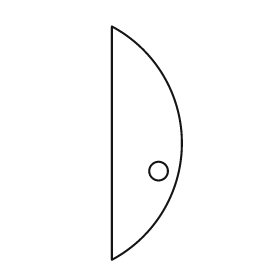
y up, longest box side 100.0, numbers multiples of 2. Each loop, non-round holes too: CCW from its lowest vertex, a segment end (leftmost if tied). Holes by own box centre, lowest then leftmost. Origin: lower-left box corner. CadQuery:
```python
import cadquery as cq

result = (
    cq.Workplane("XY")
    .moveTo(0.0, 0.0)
    .threePointArc((30.0, 50.0), (0.0, 100.0))
    .close()
    .moveTo(20.0, 38.0)
    .circle(4.0)
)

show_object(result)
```